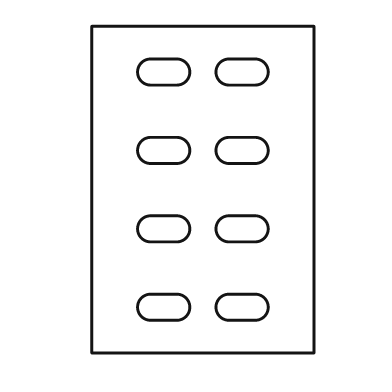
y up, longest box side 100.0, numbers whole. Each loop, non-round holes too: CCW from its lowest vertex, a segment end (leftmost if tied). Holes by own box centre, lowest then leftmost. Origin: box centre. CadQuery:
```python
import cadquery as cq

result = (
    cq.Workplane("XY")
    .moveTo(-34.0, -50.0)
    .lineTo(34.0, -50.0)
    .lineTo(34.0, 50.0)
    .lineTo(-34.0, 50.0)
    .close()
    .moveTo(-16.0, -40.0)
    .lineTo(-8.0, -40.0)
    .threePointArc((-4.0, -36.0), (-8.0, -32.0))
    .lineTo(-16.0, -32.0)
    .threePointArc((-20.0, -36.0), (-16.0, -40.0))
    .close()
    .moveTo(8.0, -40.0)
    .lineTo(16.0, -40.0)
    .threePointArc((20.0, -36.0), (16.0, -32.0))
    .lineTo(8.0, -32.0)
    .threePointArc((4.0, -36.0), (8.0, -40.0))
    .close()
    .moveTo(-16.0, -16.0)
    .lineTo(-8.0, -16.0)
    .threePointArc((-4.0, -12.0), (-8.0, -8.0))
    .lineTo(-16.0, -8.0)
    .threePointArc((-20.0, -12.0), (-16.0, -16.0))
    .close()
    .moveTo(8.0, -16.0)
    .lineTo(16.0, -16.0)
    .threePointArc((20.0, -12.0), (16.0, -8.0))
    .lineTo(8.0, -8.0)
    .threePointArc((4.0, -12.0), (8.0, -16.0))
    .close()
    .moveTo(-16.0, 8.0)
    .lineTo(-8.0, 8.0)
    .threePointArc((-4.0, 12.0), (-8.0, 16.0))
    .lineTo(-16.0, 16.0)
    .threePointArc((-20.0, 12.0), (-16.0, 8.0))
    .close()
    .moveTo(8.0, 8.0)
    .lineTo(16.0, 8.0)
    .threePointArc((20.0, 12.0), (16.0, 16.0))
    .lineTo(8.0, 16.0)
    .threePointArc((4.0, 12.0), (8.0, 8.0))
    .close()
    .moveTo(-16.0, 32.0)
    .lineTo(-8.0, 32.0)
    .threePointArc((-4.0, 36.0), (-8.0, 40.0))
    .lineTo(-16.0, 40.0)
    .threePointArc((-20.0, 36.0), (-16.0, 32.0))
    .close()
    .moveTo(8.0, 32.0)
    .lineTo(16.0, 32.0)
    .threePointArc((20.0, 36.0), (16.0, 40.0))
    .lineTo(8.0, 40.0)
    .threePointArc((4.0, 36.0), (8.0, 32.0))
    .close()
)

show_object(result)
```